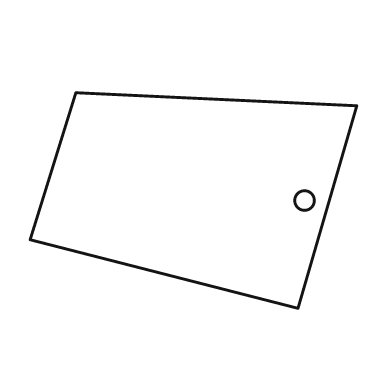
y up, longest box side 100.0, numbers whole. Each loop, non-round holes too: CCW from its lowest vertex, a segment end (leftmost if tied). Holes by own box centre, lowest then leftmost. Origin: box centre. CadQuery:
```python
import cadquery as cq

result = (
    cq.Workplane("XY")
    .moveTo(32.0, -33.0)
    .lineTo(50.0, 29.0)
    .lineTo(-36.0, 33.0)
    .lineTo(-50.0, -12.0)
    .close()
    .moveTo(34.0, 0.0)
    .circle(3.0)
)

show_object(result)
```